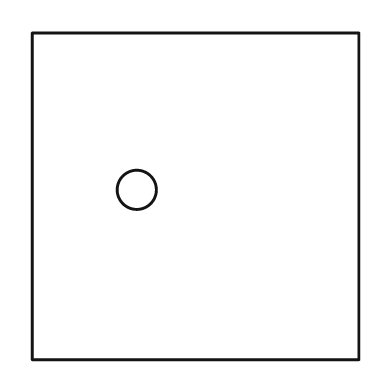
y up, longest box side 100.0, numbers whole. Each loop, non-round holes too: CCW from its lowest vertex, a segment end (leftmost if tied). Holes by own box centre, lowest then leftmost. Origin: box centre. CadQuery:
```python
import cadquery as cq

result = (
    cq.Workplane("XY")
    .moveTo(-50.0, -50.0)
    .lineTo(50.0, -50.0)
    .lineTo(50.0, 50.0)
    .lineTo(-50.0, 50.0)
    .close()
    .moveTo(-18.0, 2.0)
    .circle(6.0)
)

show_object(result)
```